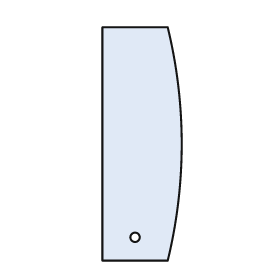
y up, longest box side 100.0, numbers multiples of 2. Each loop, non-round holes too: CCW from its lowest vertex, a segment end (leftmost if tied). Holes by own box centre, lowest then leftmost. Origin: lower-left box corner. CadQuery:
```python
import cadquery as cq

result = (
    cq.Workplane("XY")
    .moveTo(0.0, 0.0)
    .lineTo(28.0, 0.0)
    .threePointArc((34.0, 50.0), (28.0, 100.0))
    .lineTo(0.0, 100.0)
    .close()
    .moveTo(14.0, 10.0)
    .circle(2.0)
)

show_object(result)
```